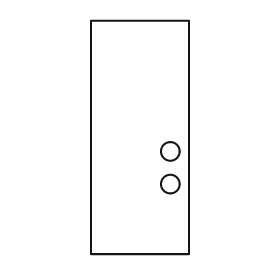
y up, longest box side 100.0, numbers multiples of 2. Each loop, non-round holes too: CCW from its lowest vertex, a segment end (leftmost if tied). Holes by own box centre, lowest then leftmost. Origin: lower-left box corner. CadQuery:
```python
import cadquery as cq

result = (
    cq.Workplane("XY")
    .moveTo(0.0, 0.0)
    .lineTo(42.0, 0.0)
    .lineTo(42.0, 100.0)
    .lineTo(0.0, 100.0)
    .close()
    .moveTo(34.0, 30.0)
    .circle(4.0)
    .moveTo(34.0, 44.0)
    .circle(4.0)
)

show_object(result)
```